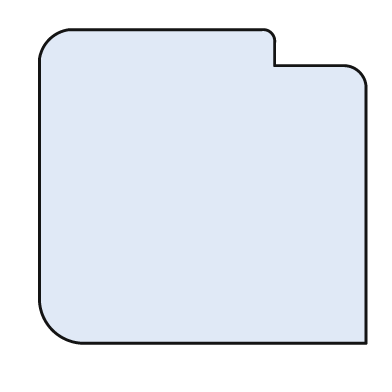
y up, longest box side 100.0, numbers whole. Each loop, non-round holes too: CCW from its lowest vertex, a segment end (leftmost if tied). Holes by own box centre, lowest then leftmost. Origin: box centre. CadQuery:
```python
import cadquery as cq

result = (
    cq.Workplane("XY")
    .moveTo(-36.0, -48.0)
    .lineTo(50.0, -48.0)
    .lineTo(50.0, 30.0)
    .threePointArc((48.0, 35.0), (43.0, 37.0))
    .lineTo(22.0, 37.0)
    .lineTo(22.0, 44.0)
    .threePointArc((21.0, 47.0), (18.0, 48.0))
    .lineTo(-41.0, 48.0)
    .threePointArc((-47.0, 45.0), (-50.0, 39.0))
    .lineTo(-50.0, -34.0)
    .threePointArc((-46.0, -44.0), (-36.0, -48.0))
    .close()
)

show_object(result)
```